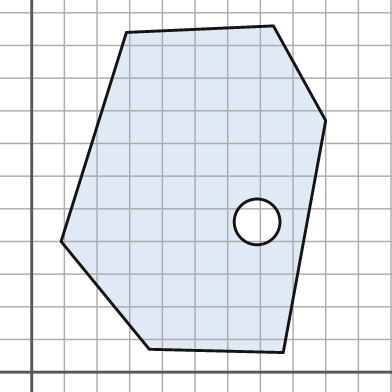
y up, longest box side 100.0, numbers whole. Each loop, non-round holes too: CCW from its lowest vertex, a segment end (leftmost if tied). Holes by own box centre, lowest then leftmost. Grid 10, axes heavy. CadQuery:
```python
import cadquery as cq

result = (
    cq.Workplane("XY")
    .moveTo(77.0, 6.0)
    .lineTo(90.0, 77.0)
    .lineTo(74.0, 106.0)
    .lineTo(29.0, 104.0)
    .lineTo(9.0, 40.0)
    .lineTo(36.0, 7.0)
    .close()
    .moveTo(69.0, 46.0)
    .circle(7.0)
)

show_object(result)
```